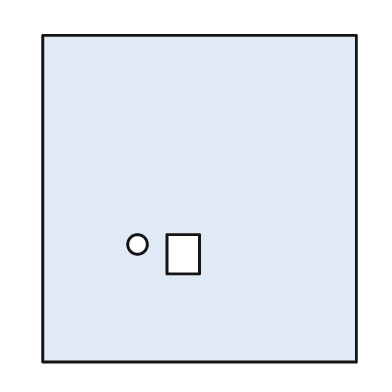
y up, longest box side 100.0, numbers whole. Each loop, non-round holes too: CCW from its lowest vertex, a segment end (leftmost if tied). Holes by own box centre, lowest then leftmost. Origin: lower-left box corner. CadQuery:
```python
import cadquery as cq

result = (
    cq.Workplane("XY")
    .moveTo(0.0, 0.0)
    .lineTo(96.0, 0.0)
    .lineTo(96.0, 100.0)
    .lineTo(0.0, 100.0)
    .close()
    .moveTo(38.0, 27.0)
    .lineTo(48.0, 27.0)
    .lineTo(48.0, 39.0)
    .lineTo(38.0, 39.0)
    .close()
    .moveTo(29.0, 36.0)
    .circle(3.0)
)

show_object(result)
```